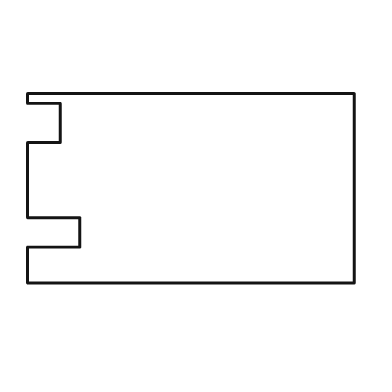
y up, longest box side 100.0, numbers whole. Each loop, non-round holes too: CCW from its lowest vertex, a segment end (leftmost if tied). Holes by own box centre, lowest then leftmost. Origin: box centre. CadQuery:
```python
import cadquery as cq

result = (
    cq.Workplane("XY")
    .moveTo(-50.0, -29.0)
    .lineTo(50.0, -29.0)
    .lineTo(50.0, 29.0)
    .lineTo(-50.0, 29.0)
    .lineTo(-50.0, 26.0)
    .lineTo(-40.0, 26.0)
    .lineTo(-40.0, 14.0)
    .lineTo(-50.0, 14.0)
    .lineTo(-50.0, -9.0)
    .lineTo(-34.0, -9.0)
    .lineTo(-34.0, -18.0)
    .lineTo(-50.0, -18.0)
    .close()
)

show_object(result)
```